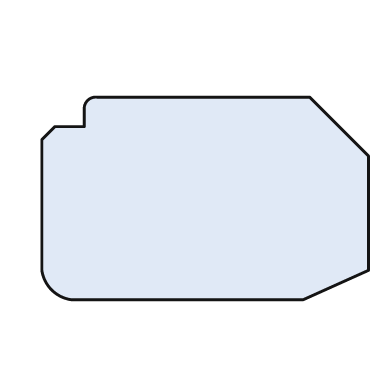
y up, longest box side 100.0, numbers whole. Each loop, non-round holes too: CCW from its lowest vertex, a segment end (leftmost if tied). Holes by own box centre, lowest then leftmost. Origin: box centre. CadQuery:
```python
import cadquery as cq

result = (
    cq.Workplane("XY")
    .moveTo(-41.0, -31.0)
    .lineTo(30.0, -31.0)
    .lineTo(50.0, -22.0)
    .lineTo(50.0, 13.0)
    .lineTo(32.0, 31.0)
    .lineTo(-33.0, 31.0)
    .threePointArc((-36.0, 30.0), (-37.0, 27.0))
    .lineTo(-37.0, 22.0)
    .lineTo(-46.0, 22.0)
    .lineTo(-50.0, 18.0)
    .lineTo(-50.0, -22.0)
    .threePointArc((-47.0, -28.0), (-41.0, -31.0))
    .close()
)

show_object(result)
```